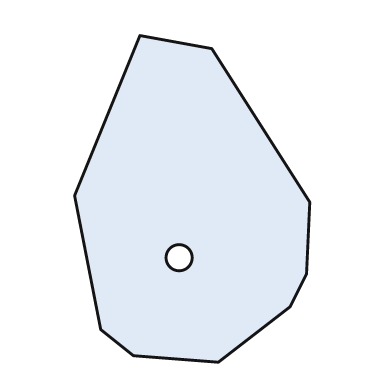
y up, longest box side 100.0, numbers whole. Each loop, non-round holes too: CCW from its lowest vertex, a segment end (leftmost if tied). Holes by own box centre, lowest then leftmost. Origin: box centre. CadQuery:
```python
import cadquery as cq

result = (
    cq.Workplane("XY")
    .moveTo(8.0, -50.0)
    .lineTo(30.0, -33.0)
    .lineTo(35.0, -23.0)
    .lineTo(36.0, -1.0)
    .lineTo(6.0, 46.0)
    .lineTo(-16.0, 50.0)
    .lineTo(-36.0, 1.0)
    .lineTo(-28.0, -40.0)
    .lineTo(-18.0, -48.0)
    .close()
    .moveTo(-4.0, -18.0)
    .circle(4.0)
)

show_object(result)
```